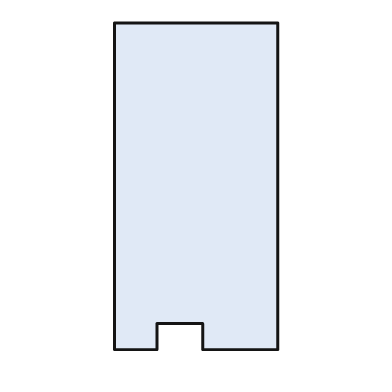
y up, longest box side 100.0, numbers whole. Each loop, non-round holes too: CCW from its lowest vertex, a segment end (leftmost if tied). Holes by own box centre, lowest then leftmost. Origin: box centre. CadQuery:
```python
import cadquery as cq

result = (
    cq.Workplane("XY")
    .moveTo(-25.0, -50.0)
    .lineTo(-12.0, -50.0)
    .lineTo(-12.0, -42.0)
    .lineTo(2.0, -42.0)
    .lineTo(2.0, -50.0)
    .lineTo(25.0, -50.0)
    .lineTo(25.0, 50.0)
    .lineTo(-25.0, 50.0)
    .close()
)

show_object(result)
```